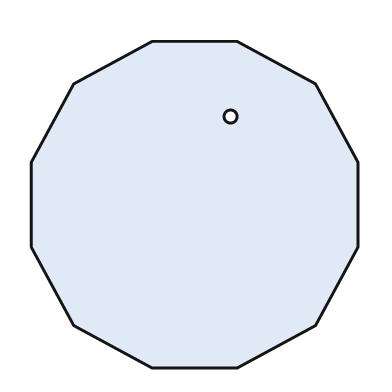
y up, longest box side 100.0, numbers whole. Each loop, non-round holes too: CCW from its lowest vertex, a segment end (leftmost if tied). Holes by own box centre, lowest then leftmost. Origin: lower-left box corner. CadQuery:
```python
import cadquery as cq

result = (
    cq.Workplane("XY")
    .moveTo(37.0, 0.0)
    .lineTo(63.0, 0.0)
    .lineTo(87.0, 13.0)
    .lineTo(100.0, 37.0)
    .lineTo(100.0, 63.0)
    .lineTo(87.0, 87.0)
    .lineTo(63.0, 100.0)
    .lineTo(37.0, 100.0)
    .lineTo(13.0, 87.0)
    .lineTo(0.0, 63.0)
    .lineTo(0.0, 37.0)
    .lineTo(13.0, 13.0)
    .close()
    .moveTo(61.0, 77.0)
    .circle(2.0)
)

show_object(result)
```